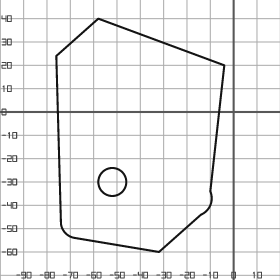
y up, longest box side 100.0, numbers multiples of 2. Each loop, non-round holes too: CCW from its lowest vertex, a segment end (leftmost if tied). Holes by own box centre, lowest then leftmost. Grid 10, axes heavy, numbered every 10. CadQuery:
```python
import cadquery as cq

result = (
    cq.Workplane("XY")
    .moveTo(-32.0, -60.0)
    .lineTo(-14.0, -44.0)
    .threePointArc((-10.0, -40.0), (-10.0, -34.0))
    .lineTo(-4.0, 20.0)
    .lineTo(-58.0, 40.0)
    .lineTo(-76.0, 24.0)
    .lineTo(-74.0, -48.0)
    .threePointArc((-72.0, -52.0), (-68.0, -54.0))
    .close()
    .moveTo(-52.0, -30.0)
    .circle(6.0)
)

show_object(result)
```